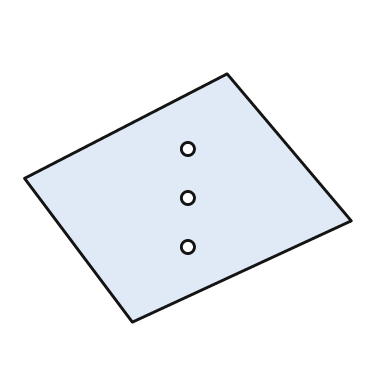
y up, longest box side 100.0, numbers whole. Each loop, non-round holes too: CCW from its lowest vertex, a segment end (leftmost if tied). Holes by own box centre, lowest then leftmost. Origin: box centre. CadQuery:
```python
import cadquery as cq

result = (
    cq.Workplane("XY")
    .moveTo(-17.0, -38.0)
    .lineTo(50.0, -7.0)
    .lineTo(12.0, 38.0)
    .lineTo(-50.0, 6.0)
    .close()
    .moveTo(0.0, -15.0)
    .circle(2.0)
    .moveTo(0.0, 0.0)
    .circle(2.0)
    .moveTo(0.0, 15.0)
    .circle(2.0)
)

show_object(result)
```